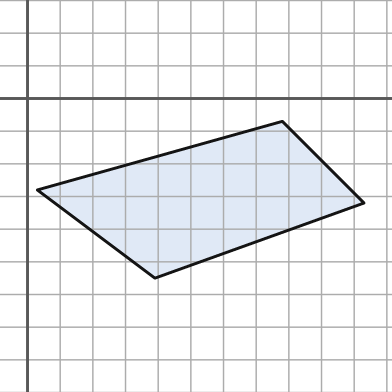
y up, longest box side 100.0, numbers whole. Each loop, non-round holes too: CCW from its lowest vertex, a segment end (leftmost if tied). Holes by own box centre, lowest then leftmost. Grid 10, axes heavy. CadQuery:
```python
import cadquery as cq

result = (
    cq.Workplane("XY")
    .moveTo(39.0, -55.0)
    .lineTo(103.0, -32.0)
    .lineTo(78.0, -7.0)
    .lineTo(3.0, -28.0)
    .close()
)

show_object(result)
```